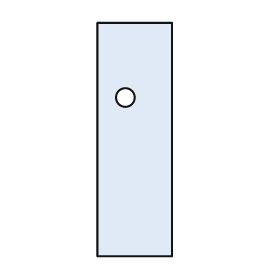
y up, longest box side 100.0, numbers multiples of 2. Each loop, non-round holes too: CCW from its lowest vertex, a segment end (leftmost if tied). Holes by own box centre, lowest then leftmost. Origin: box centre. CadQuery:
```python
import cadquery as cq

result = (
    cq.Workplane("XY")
    .moveTo(-16.0, -50.0)
    .lineTo(16.0, -50.0)
    .lineTo(16.0, 50.0)
    .lineTo(-16.0, 50.0)
    .close()
    .moveTo(-4.0, 18.0)
    .circle(4.0)
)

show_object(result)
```